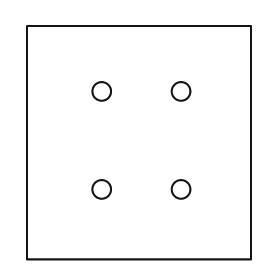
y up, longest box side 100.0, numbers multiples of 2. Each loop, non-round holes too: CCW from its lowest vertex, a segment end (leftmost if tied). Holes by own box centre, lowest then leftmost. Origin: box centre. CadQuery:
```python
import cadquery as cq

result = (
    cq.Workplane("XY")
    .moveTo(-48.0, -50.0)
    .lineTo(48.0, -50.0)
    .lineTo(48.0, 50.0)
    .lineTo(-48.0, 50.0)
    .close()
    .moveTo(-16.0, -20.0)
    .circle(4.0)
    .moveTo(18.0, -20.0)
    .circle(4.0)
    .moveTo(-16.0, 22.0)
    .circle(4.0)
    .moveTo(18.0, 22.0)
    .circle(4.0)
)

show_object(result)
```